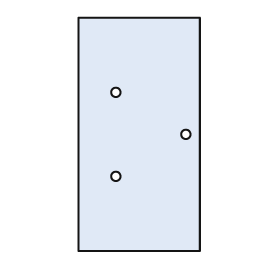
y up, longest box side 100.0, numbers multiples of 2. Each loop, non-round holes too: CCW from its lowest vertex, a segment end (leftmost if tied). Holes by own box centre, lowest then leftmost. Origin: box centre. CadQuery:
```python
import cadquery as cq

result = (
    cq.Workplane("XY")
    .moveTo(-26.0, -50.0)
    .lineTo(26.0, -50.0)
    .lineTo(26.0, 50.0)
    .lineTo(-26.0, 50.0)
    .close()
    .moveTo(-10.0, -18.0)
    .circle(2.0)
    .moveTo(20.0, 0.0)
    .circle(2.0)
    .moveTo(-10.0, 18.0)
    .circle(2.0)
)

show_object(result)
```